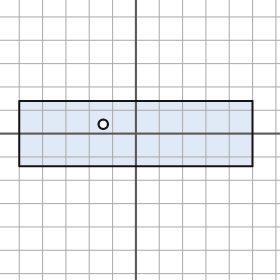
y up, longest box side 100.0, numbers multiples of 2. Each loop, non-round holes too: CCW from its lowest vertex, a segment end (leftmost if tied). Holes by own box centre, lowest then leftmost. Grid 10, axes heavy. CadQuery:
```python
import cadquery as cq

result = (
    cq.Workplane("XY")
    .moveTo(-50.0, -14.0)
    .lineTo(50.0, -14.0)
    .lineTo(50.0, 14.0)
    .lineTo(-50.0, 14.0)
    .close()
    .moveTo(-14.0, 4.0)
    .circle(2.0)
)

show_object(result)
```